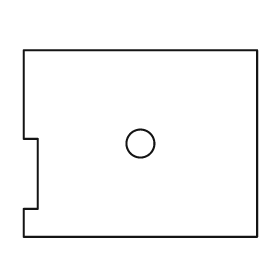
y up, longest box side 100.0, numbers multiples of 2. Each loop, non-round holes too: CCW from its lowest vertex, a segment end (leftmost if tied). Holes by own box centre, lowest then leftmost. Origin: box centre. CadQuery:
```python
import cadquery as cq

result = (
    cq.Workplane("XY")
    .moveTo(-50.0, -40.0)
    .lineTo(50.0, -40.0)
    .lineTo(50.0, 40.0)
    .lineTo(-50.0, 40.0)
    .lineTo(-50.0, 2.0)
    .lineTo(-44.0, 2.0)
    .lineTo(-44.0, -28.0)
    .lineTo(-50.0, -28.0)
    .close()
    .moveTo(0.0, 0.0)
    .circle(6.0)
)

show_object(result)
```